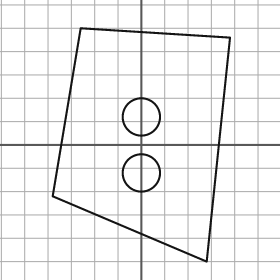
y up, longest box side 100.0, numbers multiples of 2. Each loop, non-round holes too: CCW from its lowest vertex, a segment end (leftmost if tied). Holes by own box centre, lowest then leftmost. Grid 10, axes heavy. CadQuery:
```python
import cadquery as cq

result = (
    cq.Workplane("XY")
    .moveTo(28.0, -50.0)
    .lineTo(38.0, 46.0)
    .lineTo(-26.0, 50.0)
    .lineTo(-38.0, -22.0)
    .close()
    .moveTo(0.0, -12.0)
    .circle(8.0)
    .moveTo(0.0, 12.0)
    .circle(8.0)
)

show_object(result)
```